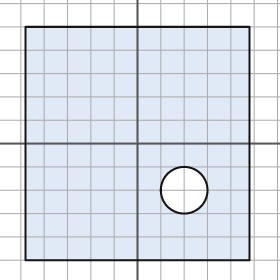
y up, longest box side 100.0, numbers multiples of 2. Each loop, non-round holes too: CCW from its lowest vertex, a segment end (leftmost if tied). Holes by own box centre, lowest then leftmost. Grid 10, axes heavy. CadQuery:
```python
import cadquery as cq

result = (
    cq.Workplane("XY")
    .moveTo(-48.0, -50.0)
    .lineTo(48.0, -50.0)
    .lineTo(48.0, 50.0)
    .lineTo(-48.0, 50.0)
    .close()
    .moveTo(20.0, -20.0)
    .circle(10.0)
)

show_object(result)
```